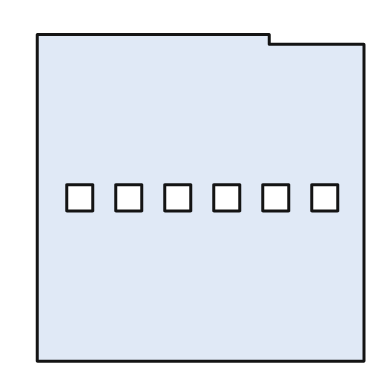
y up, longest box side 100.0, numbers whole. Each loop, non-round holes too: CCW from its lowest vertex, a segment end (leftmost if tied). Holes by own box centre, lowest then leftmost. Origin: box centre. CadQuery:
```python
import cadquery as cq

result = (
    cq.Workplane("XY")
    .moveTo(-50.0, -50.0)
    .lineTo(50.0, -50.0)
    .lineTo(50.0, 47.0)
    .lineTo(21.0, 47.0)
    .lineTo(21.0, 50.0)
    .lineTo(-50.0, 50.0)
    .close()
    .moveTo(-41.0, -4.0)
    .lineTo(-33.0, -4.0)
    .lineTo(-33.0, 4.0)
    .lineTo(-41.0, 4.0)
    .close()
    .moveTo(-26.0, -4.0)
    .lineTo(-18.0, -4.0)
    .lineTo(-18.0, 4.0)
    .lineTo(-26.0, 4.0)
    .close()
    .moveTo(-11.0, -4.0)
    .lineTo(-3.0, -4.0)
    .lineTo(-3.0, 4.0)
    .lineTo(-11.0, 4.0)
    .close()
    .moveTo(4.0, -4.0)
    .lineTo(12.0, -4.0)
    .lineTo(12.0, 4.0)
    .lineTo(4.0, 4.0)
    .close()
    .moveTo(19.0, -4.0)
    .lineTo(27.0, -4.0)
    .lineTo(27.0, 4.0)
    .lineTo(19.0, 4.0)
    .close()
    .moveTo(34.0, -4.0)
    .lineTo(42.0, -4.0)
    .lineTo(42.0, 4.0)
    .lineTo(34.0, 4.0)
    .close()
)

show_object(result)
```